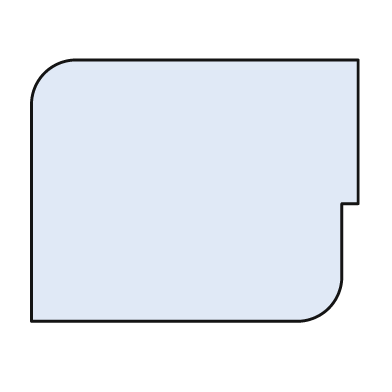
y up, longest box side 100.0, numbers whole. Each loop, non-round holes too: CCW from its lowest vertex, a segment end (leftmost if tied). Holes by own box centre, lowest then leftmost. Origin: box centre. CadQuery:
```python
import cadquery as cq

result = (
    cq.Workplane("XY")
    .moveTo(-50.0, -40.0)
    .lineTo(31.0, -40.0)
    .threePointArc((41.0, -36.0), (45.0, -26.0))
    .lineTo(45.0, -4.0)
    .lineTo(50.0, -4.0)
    .lineTo(50.0, 40.0)
    .lineTo(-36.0, 40.0)
    .threePointArc((-46.0, 36.0), (-50.0, 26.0))
    .close()
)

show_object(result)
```